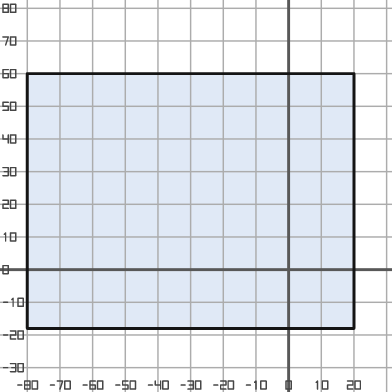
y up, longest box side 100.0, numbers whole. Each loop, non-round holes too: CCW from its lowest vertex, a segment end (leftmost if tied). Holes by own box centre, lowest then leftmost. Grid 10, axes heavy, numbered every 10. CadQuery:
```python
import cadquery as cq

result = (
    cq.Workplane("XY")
    .moveTo(-80.0, -18.0)
    .lineTo(20.0, -18.0)
    .lineTo(20.0, 60.0)
    .lineTo(-80.0, 60.0)
    .close()
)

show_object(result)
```